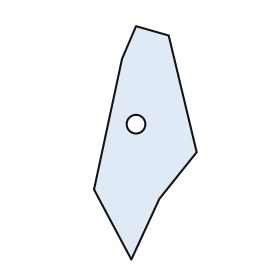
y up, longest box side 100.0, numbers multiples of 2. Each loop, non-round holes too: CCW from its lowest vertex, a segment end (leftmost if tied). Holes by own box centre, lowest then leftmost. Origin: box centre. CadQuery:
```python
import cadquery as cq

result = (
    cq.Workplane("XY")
    .moveTo(-6.0, -50.0)
    .lineTo(6.0, -24.0)
    .lineTo(22.0, -4.0)
    .lineTo(10.0, 46.0)
    .lineTo(-4.0, 50.0)
    .lineTo(-10.0, 36.0)
    .lineTo(-22.0, -20.0)
    .close()
    .moveTo(-4.0, 8.0)
    .circle(4.0)
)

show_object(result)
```